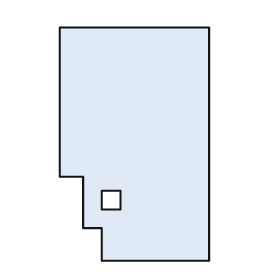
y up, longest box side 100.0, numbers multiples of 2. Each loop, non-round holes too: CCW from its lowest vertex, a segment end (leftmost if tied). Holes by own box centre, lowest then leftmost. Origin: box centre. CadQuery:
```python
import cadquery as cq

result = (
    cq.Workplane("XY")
    .moveTo(-14.0, -50.0)
    .lineTo(32.0, -50.0)
    .lineTo(32.0, 50.0)
    .lineTo(-32.0, 50.0)
    .lineTo(-32.0, -14.0)
    .lineTo(-22.0, -14.0)
    .lineTo(-22.0, -36.0)
    .lineTo(-14.0, -36.0)
    .close()
    .moveTo(-14.0, -28.0)
    .lineTo(-6.0, -28.0)
    .lineTo(-6.0, -20.0)
    .lineTo(-14.0, -20.0)
    .close()
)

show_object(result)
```